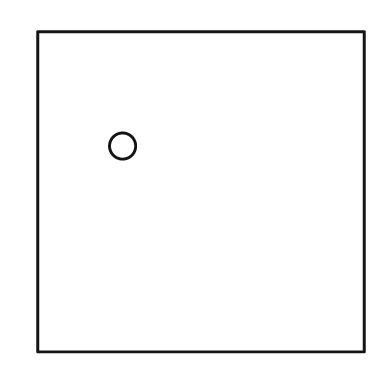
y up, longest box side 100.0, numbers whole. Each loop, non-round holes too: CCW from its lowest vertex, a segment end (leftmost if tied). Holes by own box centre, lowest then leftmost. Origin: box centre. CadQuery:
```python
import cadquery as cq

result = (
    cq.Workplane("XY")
    .moveTo(-50.0, -49.0)
    .lineTo(50.0, -49.0)
    .lineTo(50.0, 49.0)
    .lineTo(-50.0, 49.0)
    .close()
    .moveTo(-24.0, 14.0)
    .circle(4.0)
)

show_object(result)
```